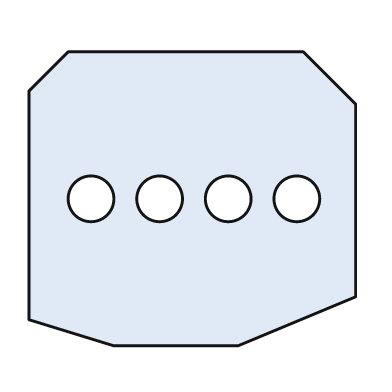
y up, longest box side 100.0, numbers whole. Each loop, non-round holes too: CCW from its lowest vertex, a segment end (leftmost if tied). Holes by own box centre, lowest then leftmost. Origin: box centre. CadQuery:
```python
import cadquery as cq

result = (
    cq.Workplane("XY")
    .moveTo(-24.0, -45.0)
    .lineTo(14.0, -45.0)
    .lineTo(50.0, -30.0)
    .lineTo(50.0, 29.0)
    .lineTo(34.0, 45.0)
    .lineTo(-38.0, 45.0)
    .lineTo(-50.0, 33.0)
    .lineTo(-50.0, -37.0)
    .close()
    .moveTo(-31.0, 0.0)
    .circle(7.0)
    .moveTo(-10.0, 0.0)
    .circle(7.0)
    .moveTo(11.0, 0.0)
    .circle(7.0)
    .moveTo(32.0, 0.0)
    .circle(7.0)
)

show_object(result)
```